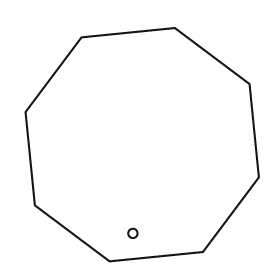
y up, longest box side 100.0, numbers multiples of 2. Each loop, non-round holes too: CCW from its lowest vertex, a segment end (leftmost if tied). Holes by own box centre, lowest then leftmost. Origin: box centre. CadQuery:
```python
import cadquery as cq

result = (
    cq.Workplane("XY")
    .moveTo(-14.0, -50.0)
    .lineTo(26.0, -46.0)
    .lineTo(50.0, -14.0)
    .lineTo(46.0, 26.0)
    .lineTo(14.0, 50.0)
    .lineTo(-26.0, 46.0)
    .lineTo(-50.0, 14.0)
    .lineTo(-46.0, -26.0)
    .close()
    .moveTo(-4.0, -38.0)
    .circle(2.0)
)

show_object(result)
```